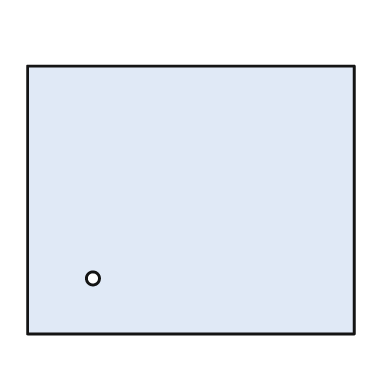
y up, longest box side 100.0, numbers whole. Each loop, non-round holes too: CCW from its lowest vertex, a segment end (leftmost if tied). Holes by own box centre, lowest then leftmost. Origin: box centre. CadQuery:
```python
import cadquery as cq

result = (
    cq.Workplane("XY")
    .moveTo(-50.0, -41.0)
    .lineTo(50.0, -41.0)
    .lineTo(50.0, 41.0)
    .lineTo(-50.0, 41.0)
    .close()
    .moveTo(-30.0, -24.0)
    .circle(2.0)
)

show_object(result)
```